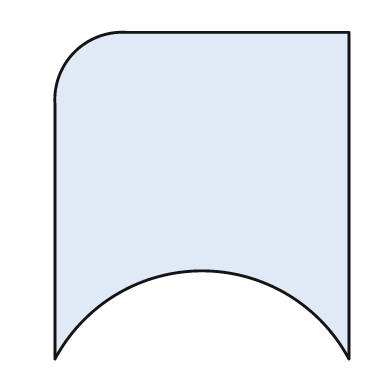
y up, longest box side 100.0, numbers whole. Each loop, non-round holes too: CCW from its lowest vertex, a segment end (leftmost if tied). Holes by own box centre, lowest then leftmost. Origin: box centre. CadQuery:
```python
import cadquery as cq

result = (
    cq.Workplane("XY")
    .moveTo(-45.0, -50.0)
    .threePointArc((0.0, -23.0), (45.0, -50.0))
    .lineTo(45.0, 50.0)
    .lineTo(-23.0, 50.0)
    .threePointArc((-39.0, 44.0), (-45.0, 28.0))
    .close()
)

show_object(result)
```